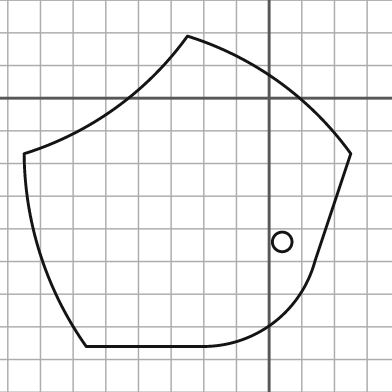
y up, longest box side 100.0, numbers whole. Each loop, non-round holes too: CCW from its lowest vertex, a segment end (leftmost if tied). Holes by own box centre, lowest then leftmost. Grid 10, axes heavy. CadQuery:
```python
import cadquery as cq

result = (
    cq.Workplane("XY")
    .moveTo(-56.0, -76.0)
    .lineTo(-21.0, -76.0)
    .threePointArc((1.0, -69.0), (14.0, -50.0))
    .lineTo(25.0, -17.0)
    .threePointArc((3.0, 5.0), (-25.0, 19.0))
    .threePointArc((-47.0, -3.0), (-75.0, -17.0))
    .threePointArc((-70.0, -48.0), (-56.0, -76.0))
    .close()
    .moveTo(4.0, -44.0)
    .circle(3.0)
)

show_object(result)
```